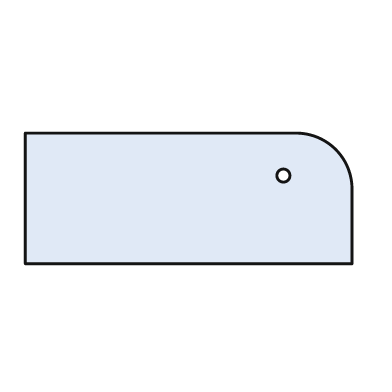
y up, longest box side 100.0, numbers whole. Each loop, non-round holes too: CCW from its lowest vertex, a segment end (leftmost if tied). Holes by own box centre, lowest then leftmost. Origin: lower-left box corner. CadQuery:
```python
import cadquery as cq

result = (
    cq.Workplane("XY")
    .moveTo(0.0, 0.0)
    .lineTo(100.0, 0.0)
    .lineTo(100.0, 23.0)
    .threePointArc((95.0, 35.0), (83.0, 40.0))
    .lineTo(0.0, 40.0)
    .close()
    .moveTo(79.0, 27.0)
    .circle(2.0)
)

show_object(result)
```